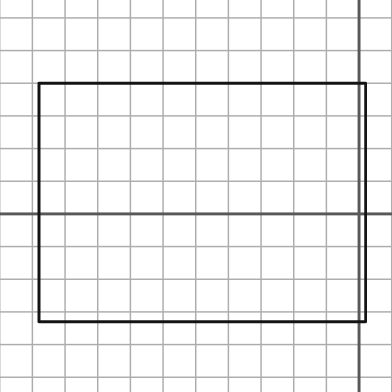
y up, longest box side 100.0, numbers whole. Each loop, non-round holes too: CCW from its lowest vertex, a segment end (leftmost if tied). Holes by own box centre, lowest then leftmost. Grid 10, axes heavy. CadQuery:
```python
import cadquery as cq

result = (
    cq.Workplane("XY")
    .moveTo(-98.0, -33.0)
    .lineTo(2.0, -33.0)
    .lineTo(2.0, 40.0)
    .lineTo(-98.0, 40.0)
    .close()
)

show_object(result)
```